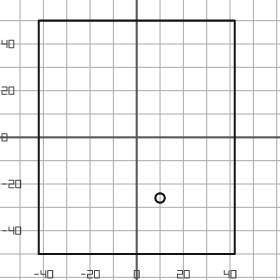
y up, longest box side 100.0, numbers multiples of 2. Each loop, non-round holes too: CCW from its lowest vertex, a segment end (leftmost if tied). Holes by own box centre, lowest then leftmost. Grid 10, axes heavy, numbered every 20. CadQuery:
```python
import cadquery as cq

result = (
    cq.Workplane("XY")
    .moveTo(-42.0, -50.0)
    .lineTo(42.0, -50.0)
    .lineTo(42.0, 50.0)
    .lineTo(-42.0, 50.0)
    .close()
    .moveTo(10.0, -26.0)
    .circle(2.0)
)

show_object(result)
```